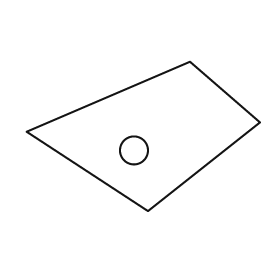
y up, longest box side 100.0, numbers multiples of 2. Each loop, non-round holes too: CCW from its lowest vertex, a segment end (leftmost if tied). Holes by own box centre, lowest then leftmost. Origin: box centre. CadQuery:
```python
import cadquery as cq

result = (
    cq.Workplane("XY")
    .moveTo(2.0, -32.0)
    .lineTo(50.0, 6.0)
    .lineTo(20.0, 32.0)
    .lineTo(-50.0, 2.0)
    .close()
    .moveTo(-4.0, -6.0)
    .circle(6.0)
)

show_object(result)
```